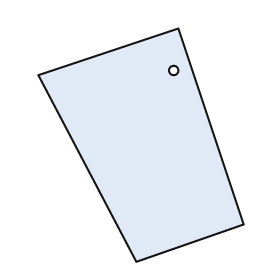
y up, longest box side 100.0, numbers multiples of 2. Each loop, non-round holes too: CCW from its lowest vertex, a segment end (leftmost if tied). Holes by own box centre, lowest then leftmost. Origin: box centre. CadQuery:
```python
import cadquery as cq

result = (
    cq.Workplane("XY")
    .moveTo(-2.0, -50.0)
    .lineTo(44.0, -34.0)
    .lineTo(16.0, 50.0)
    .lineTo(-44.0, 30.0)
    .close()
    .moveTo(14.0, 32.0)
    .circle(2.0)
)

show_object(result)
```